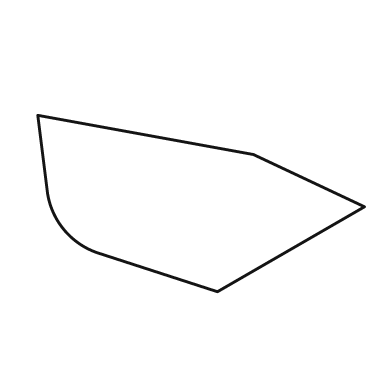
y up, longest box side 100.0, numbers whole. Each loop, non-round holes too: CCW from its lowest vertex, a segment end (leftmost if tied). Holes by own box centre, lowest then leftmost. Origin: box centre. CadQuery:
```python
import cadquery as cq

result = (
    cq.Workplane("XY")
    .moveTo(5.0, -27.0)
    .lineTo(50.0, -1.0)
    .lineTo(16.0, 15.0)
    .lineTo(-50.0, 27.0)
    .lineTo(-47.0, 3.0)
    .threePointArc((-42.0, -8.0), (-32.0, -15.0))
    .close()
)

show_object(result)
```